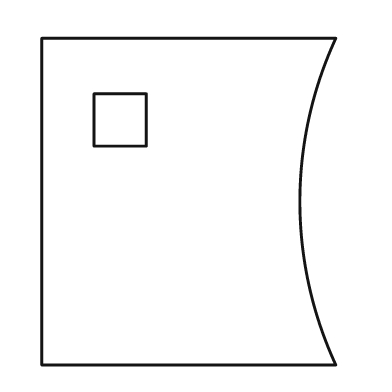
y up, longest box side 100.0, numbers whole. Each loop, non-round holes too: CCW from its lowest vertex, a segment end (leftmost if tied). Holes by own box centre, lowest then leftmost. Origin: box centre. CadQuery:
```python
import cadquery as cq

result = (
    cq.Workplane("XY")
    .moveTo(-45.0, -50.0)
    .lineTo(45.0, -50.0)
    .threePointArc((34.0, 0.0), (45.0, 50.0))
    .lineTo(-45.0, 50.0)
    .close()
    .moveTo(-29.0, 17.0)
    .lineTo(-13.0, 17.0)
    .lineTo(-13.0, 33.0)
    .lineTo(-29.0, 33.0)
    .close()
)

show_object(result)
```